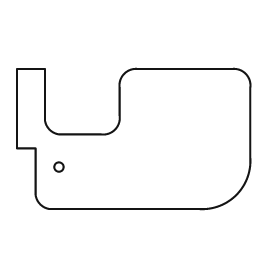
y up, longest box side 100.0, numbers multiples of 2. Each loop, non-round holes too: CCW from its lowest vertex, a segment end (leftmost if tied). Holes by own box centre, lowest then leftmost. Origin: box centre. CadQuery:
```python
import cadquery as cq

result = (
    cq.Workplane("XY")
    .moveTo(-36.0, -30.0)
    .lineTo(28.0, -30.0)
    .threePointArc((44.0, -24.0), (50.0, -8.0))
    .lineTo(50.0, 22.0)
    .threePointArc((48.0, 28.0), (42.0, 30.0))
    .lineTo(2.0, 30.0)
    .threePointArc((-4.0, 28.0), (-6.0, 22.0))
    .lineTo(-6.0, 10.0)
    .threePointArc((-8.0, 4.0), (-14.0, 2.0))
    .lineTo(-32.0, 2.0)
    .threePointArc((-36.0, 4.0), (-38.0, 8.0))
    .lineTo(-38.0, 30.0)
    .lineTo(-50.0, 30.0)
    .lineTo(-50.0, -4.0)
    .lineTo(-42.0, -4.0)
    .lineTo(-42.0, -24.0)
    .threePointArc((-40.0, -28.0), (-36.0, -30.0))
    .close()
    .moveTo(-32.0, -12.0)
    .circle(2.0)
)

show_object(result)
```